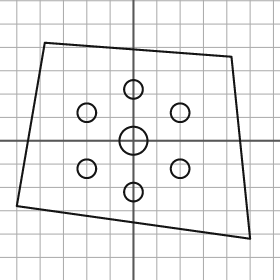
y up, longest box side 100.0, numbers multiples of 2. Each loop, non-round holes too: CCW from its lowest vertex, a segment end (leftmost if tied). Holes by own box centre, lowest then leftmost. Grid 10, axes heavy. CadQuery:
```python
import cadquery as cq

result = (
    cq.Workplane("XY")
    .moveTo(50.0, -42.0)
    .lineTo(42.0, 36.0)
    .lineTo(-38.0, 42.0)
    .lineTo(-50.0, -28.0)
    .close()
    .moveTo(0.0, -22.0)
    .circle(4.0)
    .moveTo(-20.0, -12.0)
    .circle(4.0)
    .moveTo(20.0, -12.0)
    .circle(4.0)
    .moveTo(0.0, 0.0)
    .circle(6.0)
    .moveTo(-20.0, 12.0)
    .circle(4.0)
    .moveTo(20.0, 12.0)
    .circle(4.0)
    .moveTo(0.0, 22.0)
    .circle(4.0)
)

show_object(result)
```